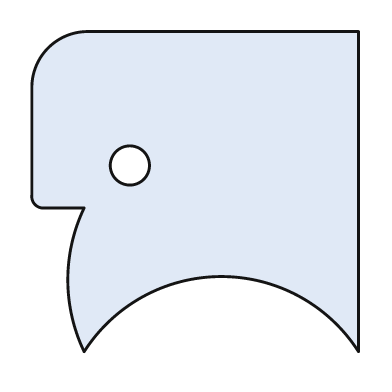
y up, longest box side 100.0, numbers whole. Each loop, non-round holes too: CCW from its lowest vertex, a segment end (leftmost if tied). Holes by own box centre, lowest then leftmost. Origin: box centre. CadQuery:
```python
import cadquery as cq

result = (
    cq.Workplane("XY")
    .moveTo(-34.0, -49.0)
    .threePointArc((8.0, -26.0), (50.0, -49.0))
    .lineTo(50.0, 49.0)
    .lineTo(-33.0, 49.0)
    .threePointArc((-45.0, 44.0), (-50.0, 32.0))
    .lineTo(-50.0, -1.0)
    .threePointArc((-49.0, -4.0), (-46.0, -5.0))
    .lineTo(-34.0, -5.0)
    .threePointArc((-39.0, -27.0), (-34.0, -49.0))
    .close()
    .moveTo(-20.0, 8.0)
    .circle(6.0)
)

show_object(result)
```